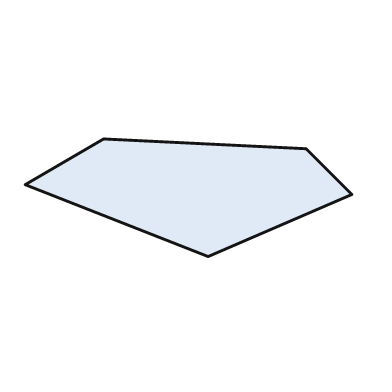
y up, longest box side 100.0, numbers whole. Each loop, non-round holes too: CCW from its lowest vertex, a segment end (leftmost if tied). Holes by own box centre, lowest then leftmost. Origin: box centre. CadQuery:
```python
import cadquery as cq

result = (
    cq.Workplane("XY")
    .moveTo(6.0, -18.0)
    .lineTo(50.0, 1.0)
    .lineTo(36.0, 15.0)
    .lineTo(-26.0, 18.0)
    .lineTo(-50.0, 4.0)
    .close()
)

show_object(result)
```